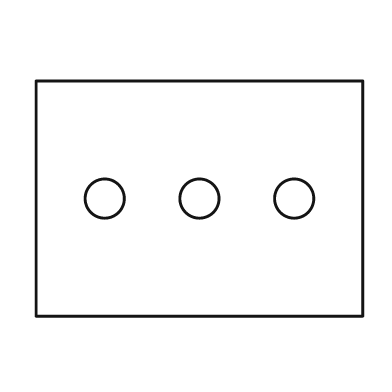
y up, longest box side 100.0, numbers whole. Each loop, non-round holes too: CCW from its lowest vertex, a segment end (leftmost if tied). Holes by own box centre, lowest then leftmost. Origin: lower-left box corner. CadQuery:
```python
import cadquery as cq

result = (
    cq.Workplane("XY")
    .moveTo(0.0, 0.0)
    .lineTo(100.0, 0.0)
    .lineTo(100.0, 72.0)
    .lineTo(0.0, 72.0)
    .close()
    .moveTo(21.0, 36.0)
    .circle(6.0)
    .moveTo(50.0, 36.0)
    .circle(6.0)
    .moveTo(79.0, 36.0)
    .circle(6.0)
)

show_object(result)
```